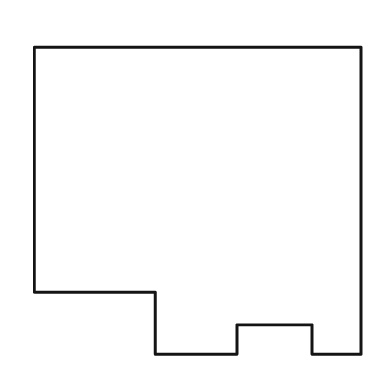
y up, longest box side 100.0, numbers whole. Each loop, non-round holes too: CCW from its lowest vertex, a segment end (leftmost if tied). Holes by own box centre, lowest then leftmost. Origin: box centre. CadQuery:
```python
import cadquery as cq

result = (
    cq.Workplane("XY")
    .moveTo(-13.0, -47.0)
    .lineTo(12.0, -47.0)
    .lineTo(12.0, -38.0)
    .lineTo(35.0, -38.0)
    .lineTo(35.0, -47.0)
    .lineTo(50.0, -47.0)
    .lineTo(50.0, 47.0)
    .lineTo(-50.0, 47.0)
    .lineTo(-50.0, -28.0)
    .lineTo(-13.0, -28.0)
    .close()
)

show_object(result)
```